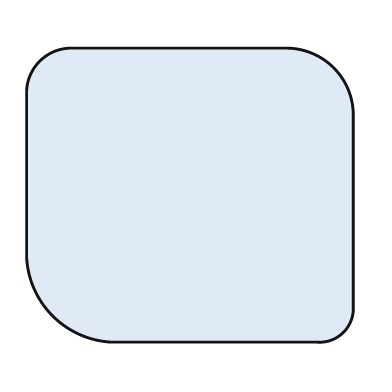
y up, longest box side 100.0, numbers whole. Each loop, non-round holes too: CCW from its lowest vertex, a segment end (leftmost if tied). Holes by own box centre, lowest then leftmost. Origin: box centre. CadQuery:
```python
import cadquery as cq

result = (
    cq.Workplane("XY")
    .moveTo(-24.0, -45.0)
    .lineTo(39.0, -45.0)
    .threePointArc((47.0, -42.0), (50.0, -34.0))
    .lineTo(50.0, 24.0)
    .threePointArc((44.0, 39.0), (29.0, 45.0))
    .lineTo(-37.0, 45.0)
    .threePointArc((-46.0, 41.0), (-50.0, 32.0))
    .lineTo(-50.0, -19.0)
    .threePointArc((-42.0, -37.0), (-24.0, -45.0))
    .close()
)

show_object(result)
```